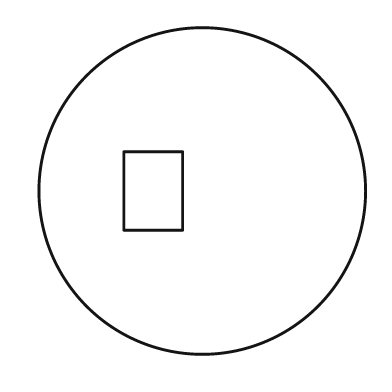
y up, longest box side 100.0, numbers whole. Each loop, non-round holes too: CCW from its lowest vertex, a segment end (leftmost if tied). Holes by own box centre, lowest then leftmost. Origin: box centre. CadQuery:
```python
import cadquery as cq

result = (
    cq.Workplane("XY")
    .moveTo(0.0, 0.0)
    .circle(50.0)
    .moveTo(-24.0, -12.0)
    .lineTo(-6.0, -12.0)
    .lineTo(-6.0, 12.0)
    .lineTo(-24.0, 12.0)
    .close()
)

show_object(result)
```